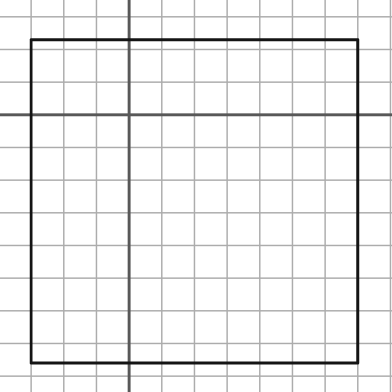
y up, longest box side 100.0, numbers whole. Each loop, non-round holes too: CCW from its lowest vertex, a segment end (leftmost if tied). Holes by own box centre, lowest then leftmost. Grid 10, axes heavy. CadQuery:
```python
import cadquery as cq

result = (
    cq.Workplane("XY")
    .moveTo(-30.0, -76.0)
    .lineTo(70.0, -76.0)
    .lineTo(70.0, 23.0)
    .lineTo(-30.0, 23.0)
    .close()
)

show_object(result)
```